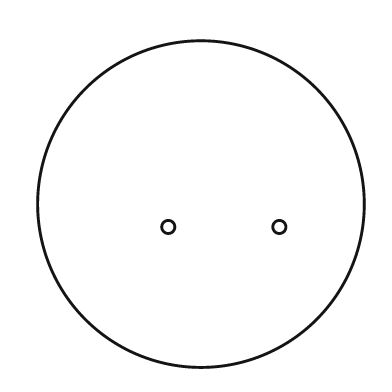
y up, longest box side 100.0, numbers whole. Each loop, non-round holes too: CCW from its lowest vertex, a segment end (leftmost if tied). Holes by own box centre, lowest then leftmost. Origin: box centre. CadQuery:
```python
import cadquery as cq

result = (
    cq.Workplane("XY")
    .moveTo(0.0, 0.0)
    .circle(50.0)
    .moveTo(-10.0, -7.0)
    .circle(2.0)
    .moveTo(24.0, -7.0)
    .circle(2.0)
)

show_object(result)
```